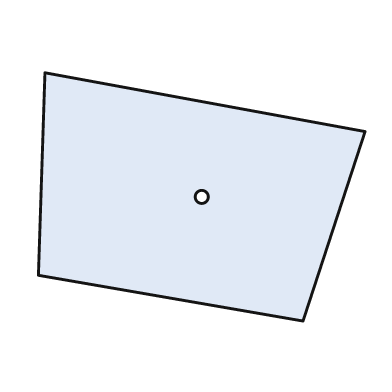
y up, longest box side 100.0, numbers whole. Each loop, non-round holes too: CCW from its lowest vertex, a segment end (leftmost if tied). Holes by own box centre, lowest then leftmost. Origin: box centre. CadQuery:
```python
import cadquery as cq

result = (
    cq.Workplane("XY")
    .moveTo(31.0, -38.0)
    .lineTo(50.0, 20.0)
    .lineTo(-48.0, 38.0)
    .lineTo(-50.0, -24.0)
    .close()
    .moveTo(0.0, 0.0)
    .circle(2.0)
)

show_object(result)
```